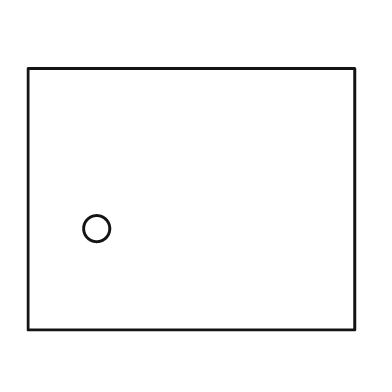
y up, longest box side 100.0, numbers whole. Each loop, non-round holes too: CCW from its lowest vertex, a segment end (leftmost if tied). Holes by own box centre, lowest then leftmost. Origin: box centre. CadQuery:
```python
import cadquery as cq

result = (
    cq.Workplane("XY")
    .moveTo(-50.0, -40.0)
    .lineTo(50.0, -40.0)
    .lineTo(50.0, 40.0)
    .lineTo(-50.0, 40.0)
    .close()
    .moveTo(-29.0, -9.0)
    .circle(4.0)
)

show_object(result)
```